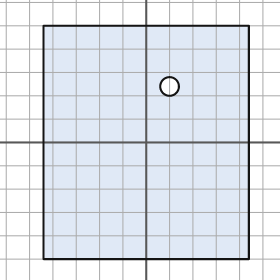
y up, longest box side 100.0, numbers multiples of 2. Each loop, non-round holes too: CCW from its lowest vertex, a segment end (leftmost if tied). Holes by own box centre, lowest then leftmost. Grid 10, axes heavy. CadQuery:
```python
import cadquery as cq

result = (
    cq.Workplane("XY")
    .moveTo(-44.0, -50.0)
    .lineTo(44.0, -50.0)
    .lineTo(44.0, 50.0)
    .lineTo(-44.0, 50.0)
    .close()
    .moveTo(10.0, 24.0)
    .circle(4.0)
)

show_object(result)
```